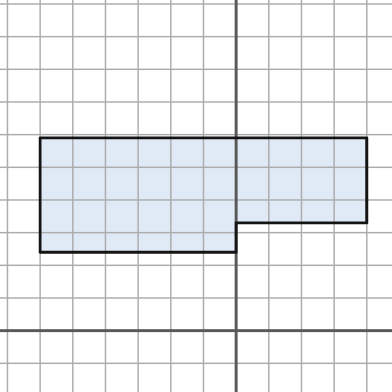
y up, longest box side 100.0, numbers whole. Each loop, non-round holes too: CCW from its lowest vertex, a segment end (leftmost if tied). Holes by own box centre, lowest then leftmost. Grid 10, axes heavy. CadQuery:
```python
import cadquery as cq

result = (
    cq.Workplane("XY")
    .moveTo(-60.0, 24.0)
    .lineTo(0.0, 24.0)
    .lineTo(0.0, 33.0)
    .lineTo(40.0, 33.0)
    .lineTo(40.0, 59.0)
    .lineTo(-60.0, 59.0)
    .close()
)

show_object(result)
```